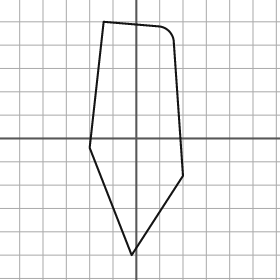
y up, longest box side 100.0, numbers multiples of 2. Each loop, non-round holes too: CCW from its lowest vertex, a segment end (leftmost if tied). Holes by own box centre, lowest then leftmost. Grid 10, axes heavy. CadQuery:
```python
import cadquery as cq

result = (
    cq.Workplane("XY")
    .moveTo(-2.0, -50.0)
    .lineTo(20.0, -16.0)
    .lineTo(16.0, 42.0)
    .threePointArc((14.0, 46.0), (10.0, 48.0))
    .lineTo(-14.0, 50.0)
    .lineTo(-20.0, -4.0)
    .close()
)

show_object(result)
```